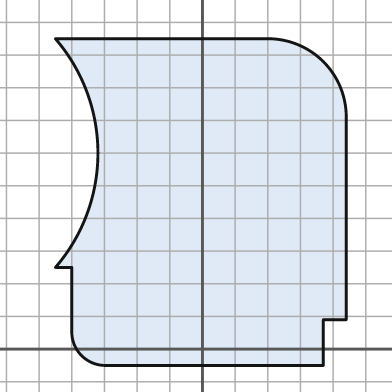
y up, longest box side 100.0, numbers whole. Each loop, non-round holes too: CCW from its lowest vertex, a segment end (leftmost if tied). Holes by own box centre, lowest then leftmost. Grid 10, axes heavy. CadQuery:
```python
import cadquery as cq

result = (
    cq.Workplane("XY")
    .moveTo(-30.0, -5.0)
    .lineTo(37.0, -5.0)
    .lineTo(37.0, 9.0)
    .lineTo(44.0, 9.0)
    .lineTo(44.0, 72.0)
    .threePointArc((37.0, 88.0), (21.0, 95.0))
    .lineTo(-45.0, 95.0)
    .threePointArc((-32.0, 60.0), (-45.0, 25.0))
    .lineTo(-40.0, 25.0)
    .lineTo(-40.0, 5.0)
    .threePointArc((-37.0, -2.0), (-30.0, -5.0))
    .close()
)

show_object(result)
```